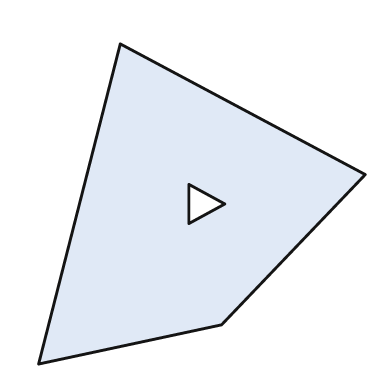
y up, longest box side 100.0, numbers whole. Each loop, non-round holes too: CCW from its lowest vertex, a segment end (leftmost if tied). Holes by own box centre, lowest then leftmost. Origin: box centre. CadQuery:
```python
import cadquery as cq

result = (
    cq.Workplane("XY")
    .moveTo(-50.0, -49.0)
    .lineTo(6.0, -37.0)
    .lineTo(50.0, 9.0)
    .lineTo(-25.0, 49.0)
    .close()
    .moveTo(-4.0, -6.0)
    .lineTo(7.0, 0.0)
    .lineTo(-4.0, 6.0)
    .close()
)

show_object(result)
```